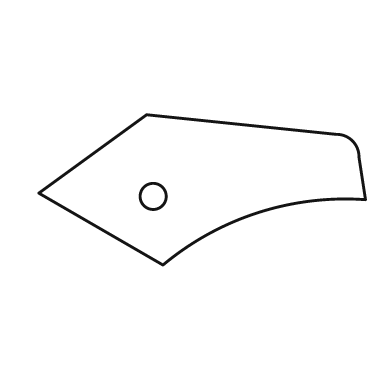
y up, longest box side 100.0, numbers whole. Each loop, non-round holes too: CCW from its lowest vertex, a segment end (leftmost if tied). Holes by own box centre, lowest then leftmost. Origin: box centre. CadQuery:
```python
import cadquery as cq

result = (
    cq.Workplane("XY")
    .moveTo(-12.0, -23.0)
    .threePointArc((17.0, -7.0), (50.0, -3.0))
    .lineTo(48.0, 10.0)
    .threePointArc((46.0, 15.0), (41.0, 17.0))
    .lineTo(-17.0, 23.0)
    .lineTo(-50.0, -1.0)
    .close()
    .moveTo(-15.0, -2.0)
    .circle(4.0)
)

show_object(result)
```